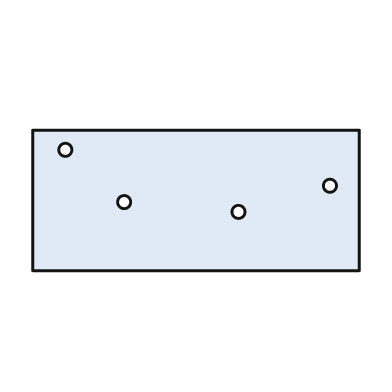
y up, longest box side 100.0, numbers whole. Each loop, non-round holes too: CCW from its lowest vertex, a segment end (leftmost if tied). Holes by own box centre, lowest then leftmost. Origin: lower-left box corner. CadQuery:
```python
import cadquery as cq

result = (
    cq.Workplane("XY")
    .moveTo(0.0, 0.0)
    .lineTo(100.0, 0.0)
    .lineTo(100.0, 43.0)
    .lineTo(0.0, 43.0)
    .close()
    .moveTo(63.0, 18.0)
    .circle(2.0)
    .moveTo(28.0, 21.0)
    .circle(2.0)
    .moveTo(91.0, 26.0)
    .circle(2.0)
    .moveTo(10.0, 37.0)
    .circle(2.0)
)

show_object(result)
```